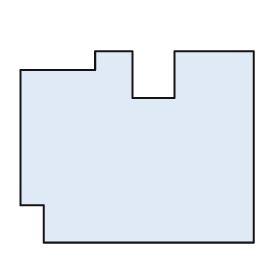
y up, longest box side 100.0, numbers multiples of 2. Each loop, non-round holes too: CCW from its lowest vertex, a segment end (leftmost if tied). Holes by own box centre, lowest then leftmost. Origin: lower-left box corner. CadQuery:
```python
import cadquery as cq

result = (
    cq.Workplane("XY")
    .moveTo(10.0, 0.0)
    .lineTo(100.0, 0.0)
    .lineTo(100.0, 82.0)
    .lineTo(66.0, 82.0)
    .lineTo(66.0, 62.0)
    .lineTo(48.0, 62.0)
    .lineTo(48.0, 82.0)
    .lineTo(32.0, 82.0)
    .lineTo(32.0, 74.0)
    .lineTo(0.0, 74.0)
    .lineTo(0.0, 16.0)
    .lineTo(10.0, 16.0)
    .close()
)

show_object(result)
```